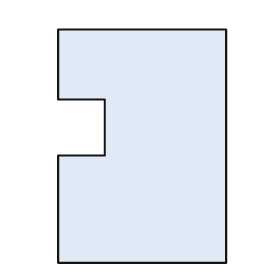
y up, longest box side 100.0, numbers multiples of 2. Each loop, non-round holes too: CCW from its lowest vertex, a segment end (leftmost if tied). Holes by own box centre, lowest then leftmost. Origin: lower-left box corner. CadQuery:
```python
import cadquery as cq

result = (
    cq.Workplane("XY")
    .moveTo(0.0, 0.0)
    .lineTo(72.0, 0.0)
    .lineTo(72.0, 100.0)
    .lineTo(0.0, 100.0)
    .lineTo(0.0, 70.0)
    .lineTo(20.0, 70.0)
    .lineTo(20.0, 46.0)
    .lineTo(0.0, 46.0)
    .close()
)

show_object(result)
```